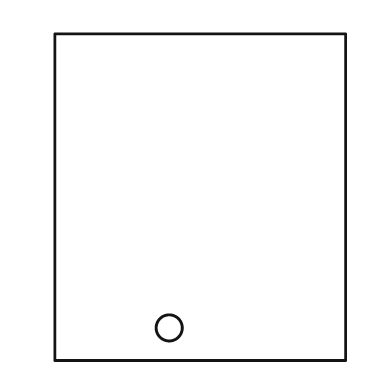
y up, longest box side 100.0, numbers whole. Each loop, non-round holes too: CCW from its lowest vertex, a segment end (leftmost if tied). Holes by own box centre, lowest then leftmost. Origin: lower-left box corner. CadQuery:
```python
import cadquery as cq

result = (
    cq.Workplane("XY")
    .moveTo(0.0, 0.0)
    .lineTo(89.0, 0.0)
    .lineTo(89.0, 100.0)
    .lineTo(0.0, 100.0)
    .close()
    .moveTo(35.0, 10.0)
    .circle(4.0)
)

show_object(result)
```